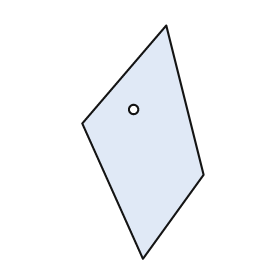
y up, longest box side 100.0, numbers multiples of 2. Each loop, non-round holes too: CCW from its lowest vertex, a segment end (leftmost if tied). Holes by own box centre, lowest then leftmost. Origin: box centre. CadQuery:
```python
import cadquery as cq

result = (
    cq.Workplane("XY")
    .moveTo(0.0, -50.0)
    .lineTo(26.0, -14.0)
    .lineTo(10.0, 50.0)
    .lineTo(-26.0, 8.0)
    .close()
    .moveTo(-4.0, 14.0)
    .circle(2.0)
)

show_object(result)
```